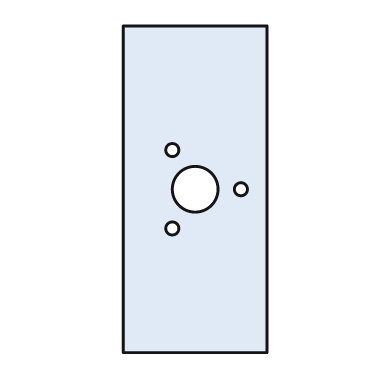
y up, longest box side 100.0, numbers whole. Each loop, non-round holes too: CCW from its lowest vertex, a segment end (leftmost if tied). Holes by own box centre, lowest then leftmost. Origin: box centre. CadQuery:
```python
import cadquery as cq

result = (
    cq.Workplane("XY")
    .moveTo(-22.0, -50.0)
    .lineTo(22.0, -50.0)
    .lineTo(22.0, 50.0)
    .lineTo(-22.0, 50.0)
    .close()
    .moveTo(-7.0, -12.0)
    .circle(2.0)
    .moveTo(0.0, 0.0)
    .circle(7.0)
    .moveTo(14.0, 0.0)
    .circle(2.0)
    .moveTo(-7.0, 12.0)
    .circle(2.0)
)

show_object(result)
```